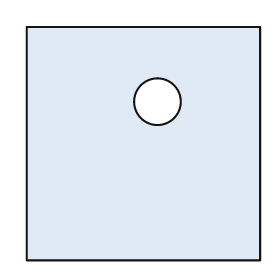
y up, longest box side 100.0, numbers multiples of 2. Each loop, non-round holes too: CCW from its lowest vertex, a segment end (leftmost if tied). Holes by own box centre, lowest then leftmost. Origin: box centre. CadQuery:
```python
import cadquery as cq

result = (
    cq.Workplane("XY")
    .moveTo(-50.0, -50.0)
    .lineTo(50.0, -50.0)
    .lineTo(50.0, 50.0)
    .lineTo(-50.0, 50.0)
    .close()
    .moveTo(6.0, 18.0)
    .circle(10.0)
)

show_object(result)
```